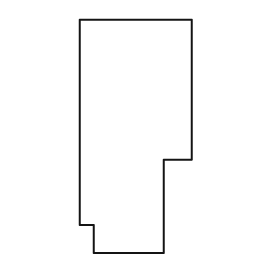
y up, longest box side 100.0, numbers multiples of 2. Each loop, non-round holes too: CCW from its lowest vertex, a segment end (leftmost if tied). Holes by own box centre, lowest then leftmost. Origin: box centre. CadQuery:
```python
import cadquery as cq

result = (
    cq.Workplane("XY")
    .moveTo(-18.0, -50.0)
    .lineTo(12.0, -50.0)
    .lineTo(12.0, -10.0)
    .lineTo(24.0, -10.0)
    .lineTo(24.0, 50.0)
    .lineTo(-24.0, 50.0)
    .lineTo(-24.0, -38.0)
    .lineTo(-18.0, -38.0)
    .close()
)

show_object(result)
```